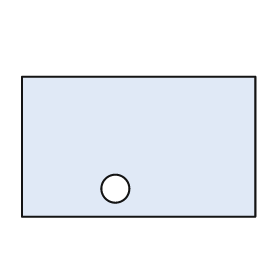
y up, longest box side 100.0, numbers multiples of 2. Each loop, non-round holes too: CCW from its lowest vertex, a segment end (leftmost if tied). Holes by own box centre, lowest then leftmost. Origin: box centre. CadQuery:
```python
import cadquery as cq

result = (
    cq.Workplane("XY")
    .moveTo(-50.0, -30.0)
    .lineTo(50.0, -30.0)
    .lineTo(50.0, 30.0)
    .lineTo(-50.0, 30.0)
    .close()
    .moveTo(-10.0, -18.0)
    .circle(6.0)
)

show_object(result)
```